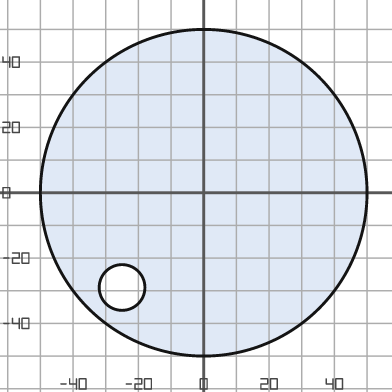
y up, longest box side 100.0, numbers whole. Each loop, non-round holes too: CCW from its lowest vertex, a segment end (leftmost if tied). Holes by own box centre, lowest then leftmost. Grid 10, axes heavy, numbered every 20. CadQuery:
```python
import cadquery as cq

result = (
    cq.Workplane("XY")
    .moveTo(0.0, 0.0)
    .circle(50.0)
    .moveTo(-25.0, -29.0)
    .circle(7.0)
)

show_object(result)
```